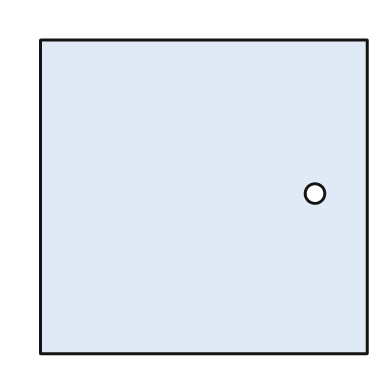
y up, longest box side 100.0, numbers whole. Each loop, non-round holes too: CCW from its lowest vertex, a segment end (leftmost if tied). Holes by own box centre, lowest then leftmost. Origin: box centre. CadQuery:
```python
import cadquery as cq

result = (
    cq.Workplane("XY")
    .moveTo(-50.0, -48.0)
    .lineTo(50.0, -48.0)
    .lineTo(50.0, 48.0)
    .lineTo(-50.0, 48.0)
    .close()
    .moveTo(34.0, 1.0)
    .circle(3.0)
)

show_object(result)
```